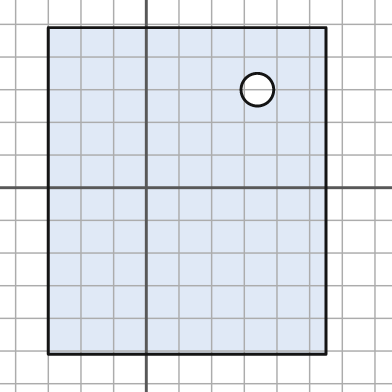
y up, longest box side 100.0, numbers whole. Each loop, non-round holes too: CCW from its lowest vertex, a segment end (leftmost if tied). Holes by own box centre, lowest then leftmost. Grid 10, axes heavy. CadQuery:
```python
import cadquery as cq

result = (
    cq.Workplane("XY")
    .moveTo(-30.0, -51.0)
    .lineTo(55.0, -51.0)
    .lineTo(55.0, 49.0)
    .lineTo(-30.0, 49.0)
    .close()
    .moveTo(34.0, 30.0)
    .circle(5.0)
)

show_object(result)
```